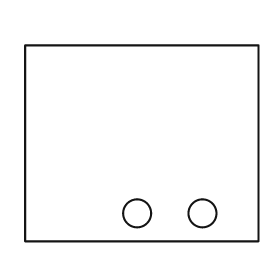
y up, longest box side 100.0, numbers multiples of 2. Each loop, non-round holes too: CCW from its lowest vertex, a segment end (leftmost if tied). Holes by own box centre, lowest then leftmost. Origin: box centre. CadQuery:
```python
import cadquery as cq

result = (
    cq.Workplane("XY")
    .moveTo(-50.0, -42.0)
    .lineTo(50.0, -42.0)
    .lineTo(50.0, 42.0)
    .lineTo(-50.0, 42.0)
    .close()
    .moveTo(-2.0, -30.0)
    .circle(6.0)
    .moveTo(26.0, -30.0)
    .circle(6.0)
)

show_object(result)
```